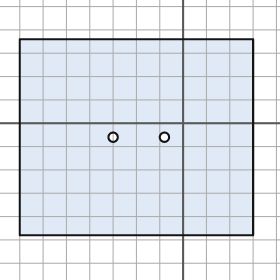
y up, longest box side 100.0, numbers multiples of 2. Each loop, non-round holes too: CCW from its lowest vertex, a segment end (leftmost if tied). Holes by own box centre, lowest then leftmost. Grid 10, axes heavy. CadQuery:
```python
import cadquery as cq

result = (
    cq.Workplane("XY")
    .moveTo(-70.0, -48.0)
    .lineTo(30.0, -48.0)
    .lineTo(30.0, 36.0)
    .lineTo(-70.0, 36.0)
    .close()
    .moveTo(-30.0, -6.0)
    .circle(2.0)
    .moveTo(-8.0, -6.0)
    .circle(2.0)
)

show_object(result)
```